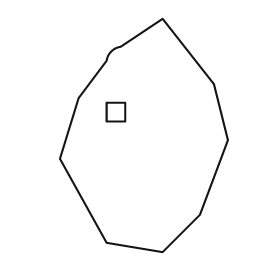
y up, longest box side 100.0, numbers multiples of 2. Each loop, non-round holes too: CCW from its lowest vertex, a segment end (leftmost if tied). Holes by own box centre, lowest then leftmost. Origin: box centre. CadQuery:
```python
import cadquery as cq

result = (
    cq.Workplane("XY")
    .moveTo(8.0, -50.0)
    .lineTo(24.0, -34.0)
    .lineTo(36.0, -2.0)
    .lineTo(30.0, 22.0)
    .lineTo(8.0, 50.0)
    .lineTo(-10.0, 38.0)
    .threePointArc((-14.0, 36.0), (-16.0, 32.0))
    .lineTo(-28.0, 16.0)
    .lineTo(-36.0, -10.0)
    .lineTo(-16.0, -46.0)
    .close()
    .moveTo(-16.0, 6.0)
    .lineTo(-8.0, 6.0)
    .lineTo(-8.0, 14.0)
    .lineTo(-16.0, 14.0)
    .close()
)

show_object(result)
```